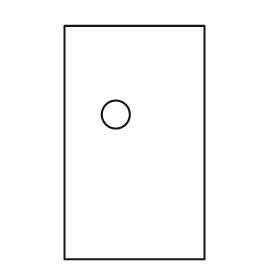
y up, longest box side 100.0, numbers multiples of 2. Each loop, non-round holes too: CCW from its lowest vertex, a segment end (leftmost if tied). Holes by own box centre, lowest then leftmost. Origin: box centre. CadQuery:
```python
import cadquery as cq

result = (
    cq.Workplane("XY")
    .moveTo(-30.0, -50.0)
    .lineTo(30.0, -50.0)
    .lineTo(30.0, 50.0)
    .lineTo(-30.0, 50.0)
    .close()
    .moveTo(-8.0, 12.0)
    .circle(6.0)
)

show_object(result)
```